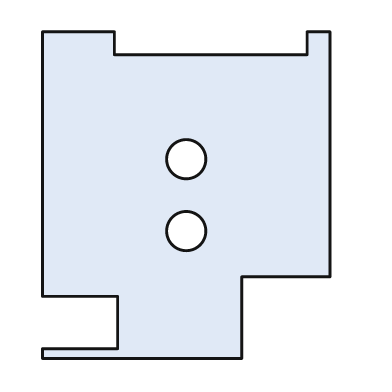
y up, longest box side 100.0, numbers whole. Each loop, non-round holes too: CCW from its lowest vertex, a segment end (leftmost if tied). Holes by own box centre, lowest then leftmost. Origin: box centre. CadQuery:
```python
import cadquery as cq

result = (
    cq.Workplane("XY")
    .moveTo(-44.0, -50.0)
    .lineTo(17.0, -50.0)
    .lineTo(17.0, -25.0)
    .lineTo(44.0, -25.0)
    .lineTo(44.0, 50.0)
    .lineTo(37.0, 50.0)
    .lineTo(37.0, 43.0)
    .lineTo(-22.0, 43.0)
    .lineTo(-22.0, 50.0)
    .lineTo(-44.0, 50.0)
    .lineTo(-44.0, -31.0)
    .lineTo(-21.0, -31.0)
    .lineTo(-21.0, -47.0)
    .lineTo(-44.0, -47.0)
    .close()
    .moveTo(0.0, -11.0)
    .circle(6.0)
    .moveTo(0.0, 11.0)
    .circle(6.0)
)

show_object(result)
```